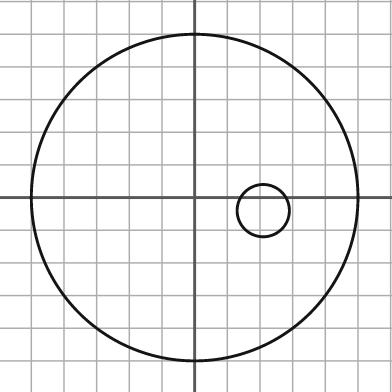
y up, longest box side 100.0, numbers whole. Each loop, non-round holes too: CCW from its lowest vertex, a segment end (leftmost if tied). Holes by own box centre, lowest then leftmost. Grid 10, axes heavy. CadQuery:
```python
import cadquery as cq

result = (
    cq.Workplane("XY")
    .moveTo(0.0, 0.0)
    .circle(50.0)
    .moveTo(21.0, -4.0)
    .circle(8.0)
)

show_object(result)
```